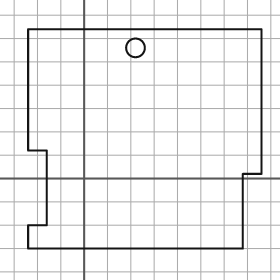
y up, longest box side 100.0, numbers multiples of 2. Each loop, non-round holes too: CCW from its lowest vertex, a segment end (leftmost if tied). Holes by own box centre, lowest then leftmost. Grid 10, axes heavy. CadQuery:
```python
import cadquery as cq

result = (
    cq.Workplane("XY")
    .moveTo(-24.0, -30.0)
    .lineTo(68.0, -30.0)
    .lineTo(68.0, 2.0)
    .lineTo(76.0, 2.0)
    .lineTo(76.0, 64.0)
    .lineTo(-24.0, 64.0)
    .lineTo(-24.0, 12.0)
    .lineTo(-16.0, 12.0)
    .lineTo(-16.0, -20.0)
    .lineTo(-24.0, -20.0)
    .close()
    .moveTo(22.0, 56.0)
    .circle(4.0)
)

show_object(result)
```